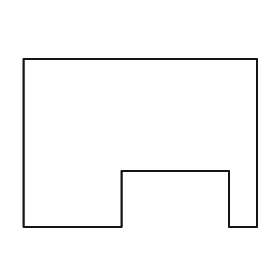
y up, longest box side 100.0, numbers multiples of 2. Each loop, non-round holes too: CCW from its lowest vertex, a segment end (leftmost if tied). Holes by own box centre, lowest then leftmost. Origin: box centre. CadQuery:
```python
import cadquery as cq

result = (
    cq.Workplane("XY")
    .moveTo(-50.0, -36.0)
    .lineTo(-8.0, -36.0)
    .lineTo(-8.0, -12.0)
    .lineTo(38.0, -12.0)
    .lineTo(38.0, -36.0)
    .lineTo(50.0, -36.0)
    .lineTo(50.0, 36.0)
    .lineTo(-50.0, 36.0)
    .close()
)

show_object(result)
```